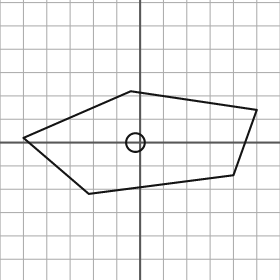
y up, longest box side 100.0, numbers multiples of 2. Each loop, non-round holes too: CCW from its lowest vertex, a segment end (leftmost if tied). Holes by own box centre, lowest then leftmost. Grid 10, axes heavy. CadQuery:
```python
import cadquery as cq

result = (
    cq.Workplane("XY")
    .moveTo(-22.0, -22.0)
    .lineTo(40.0, -14.0)
    .lineTo(50.0, 14.0)
    .lineTo(-4.0, 22.0)
    .lineTo(-50.0, 2.0)
    .close()
    .moveTo(-2.0, 0.0)
    .circle(4.0)
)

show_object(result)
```